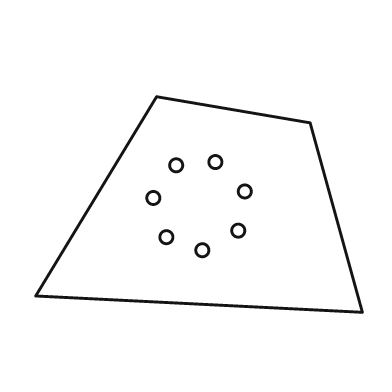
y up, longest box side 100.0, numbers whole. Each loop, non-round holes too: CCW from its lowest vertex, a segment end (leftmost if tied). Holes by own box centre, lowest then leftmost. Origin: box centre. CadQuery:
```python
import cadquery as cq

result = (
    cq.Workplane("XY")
    .moveTo(50.0, -33.0)
    .lineTo(34.0, 25.0)
    .lineTo(-13.0, 33.0)
    .lineTo(-50.0, -28.0)
    .close()
    .moveTo(1.0, -14.0)
    .circle(2.0)
    .moveTo(-10.0, -10.0)
    .circle(2.0)
    .moveTo(12.0, -8.0)
    .circle(2.0)
    .moveTo(-14.0, 2.0)
    .circle(2.0)
    .moveTo(14.0, 4.0)
    .circle(2.0)
    .moveTo(-7.0, 12.0)
    .circle(2.0)
    .moveTo(5.0, 13.0)
    .circle(2.0)
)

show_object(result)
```